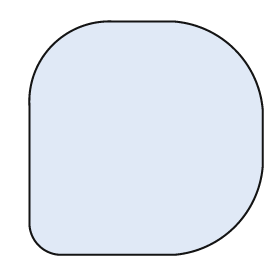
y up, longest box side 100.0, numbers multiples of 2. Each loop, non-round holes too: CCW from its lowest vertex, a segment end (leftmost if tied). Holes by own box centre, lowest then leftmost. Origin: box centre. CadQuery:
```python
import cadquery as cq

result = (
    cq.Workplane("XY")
    .moveTo(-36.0, -50.0)
    .lineTo(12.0, -50.0)
    .threePointArc((38.0, -38.0), (50.0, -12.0))
    .lineTo(50.0, 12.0)
    .threePointArc((38.0, 38.0), (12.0, 50.0))
    .lineTo(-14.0, 50.0)
    .threePointArc((-40.0, 40.0), (-50.0, 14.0))
    .lineTo(-50.0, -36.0)
    .threePointArc((-46.0, -46.0), (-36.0, -50.0))
    .close()
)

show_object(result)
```